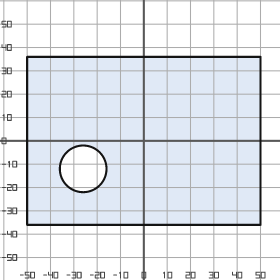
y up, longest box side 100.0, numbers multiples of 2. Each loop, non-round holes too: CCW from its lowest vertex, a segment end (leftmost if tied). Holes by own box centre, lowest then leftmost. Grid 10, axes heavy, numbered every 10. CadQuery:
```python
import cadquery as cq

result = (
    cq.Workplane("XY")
    .moveTo(-50.0, -36.0)
    .lineTo(50.0, -36.0)
    .lineTo(50.0, 36.0)
    .lineTo(-50.0, 36.0)
    .close()
    .moveTo(-26.0, -12.0)
    .circle(10.0)
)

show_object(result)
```